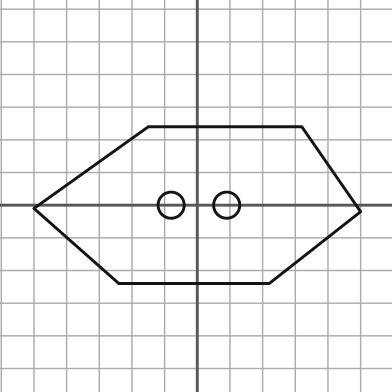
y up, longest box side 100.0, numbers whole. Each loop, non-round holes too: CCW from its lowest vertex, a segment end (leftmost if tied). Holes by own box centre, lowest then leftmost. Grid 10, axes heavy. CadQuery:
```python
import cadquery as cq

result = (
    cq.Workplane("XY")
    .moveTo(-24.0, -24.0)
    .lineTo(22.0, -24.0)
    .lineTo(50.0, -2.0)
    .lineTo(32.0, 24.0)
    .lineTo(-15.0, 24.0)
    .lineTo(-50.0, -1.0)
    .close()
    .moveTo(-8.0, 0.0)
    .circle(4.0)
    .moveTo(9.0, 0.0)
    .circle(4.0)
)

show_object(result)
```